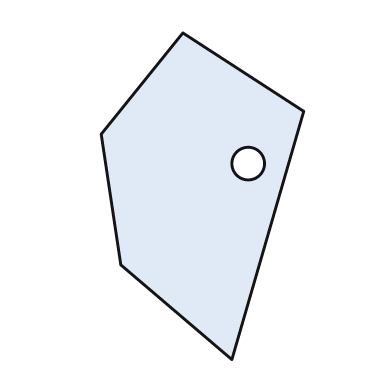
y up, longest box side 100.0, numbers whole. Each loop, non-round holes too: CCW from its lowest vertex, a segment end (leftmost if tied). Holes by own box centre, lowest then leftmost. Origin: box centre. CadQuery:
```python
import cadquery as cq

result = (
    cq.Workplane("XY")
    .moveTo(9.0, -50.0)
    .lineTo(31.0, 26.0)
    .lineTo(-6.0, 50.0)
    .lineTo(-31.0, 19.0)
    .lineTo(-25.0, -21.0)
    .close()
    .moveTo(14.0, 10.0)
    .circle(5.0)
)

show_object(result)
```